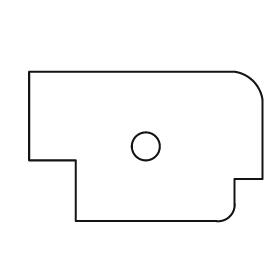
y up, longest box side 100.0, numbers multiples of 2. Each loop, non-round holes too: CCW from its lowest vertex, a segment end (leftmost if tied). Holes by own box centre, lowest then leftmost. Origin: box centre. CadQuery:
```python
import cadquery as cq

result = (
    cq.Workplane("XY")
    .moveTo(-30.0, -32.0)
    .lineTo(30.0, -32.0)
    .threePointArc((36.0, -30.0), (38.0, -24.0))
    .lineTo(38.0, -14.0)
    .lineTo(50.0, -14.0)
    .lineTo(50.0, 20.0)
    .threePointArc((46.0, 28.0), (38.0, 32.0))
    .lineTo(-50.0, 32.0)
    .lineTo(-50.0, -6.0)
    .lineTo(-30.0, -6.0)
    .close()
    .moveTo(0.0, 0.0)
    .circle(6.0)
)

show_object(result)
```